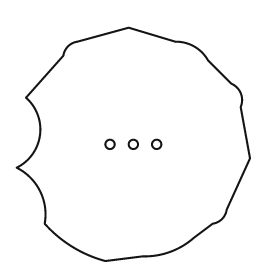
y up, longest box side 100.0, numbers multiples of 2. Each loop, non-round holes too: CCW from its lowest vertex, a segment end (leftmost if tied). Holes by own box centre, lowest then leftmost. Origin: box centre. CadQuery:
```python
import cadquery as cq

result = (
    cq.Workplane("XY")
    .moveTo(-12.0, -50.0)
    .lineTo(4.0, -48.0)
    .threePointArc((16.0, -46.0), (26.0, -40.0))
    .lineTo(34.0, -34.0)
    .threePointArc((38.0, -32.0), (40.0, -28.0))
    .lineTo(50.0, -6.0)
    .lineTo(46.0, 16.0)
    .threePointArc((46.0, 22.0), (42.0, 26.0))
    .lineTo(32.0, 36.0)
    .threePointArc((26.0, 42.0), (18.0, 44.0))
    .lineTo(-2.0, 50.0)
    .lineTo(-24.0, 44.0)
    .threePointArc((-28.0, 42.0), (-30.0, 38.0))
    .lineTo(-46.0, 20.0)
    .threePointArc((-40.0, 4.0), (-50.0, -10.0))
    .threePointArc((-40.0, -20.0), (-38.0, -34.0))
    .threePointArc((-26.0, -44.0), (-12.0, -50.0))
    .close()
    .moveTo(-10.0, 0.0)
    .circle(2.0)
    .moveTo(0.0, 0.0)
    .circle(2.0)
    .moveTo(10.0, 0.0)
    .circle(2.0)
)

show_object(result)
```